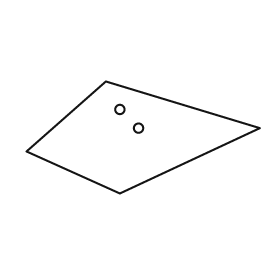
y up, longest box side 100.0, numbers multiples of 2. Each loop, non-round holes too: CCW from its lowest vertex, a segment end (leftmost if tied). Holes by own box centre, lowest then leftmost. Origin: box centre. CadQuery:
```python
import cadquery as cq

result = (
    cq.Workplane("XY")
    .moveTo(-10.0, -24.0)
    .lineTo(50.0, 4.0)
    .lineTo(-16.0, 24.0)
    .lineTo(-50.0, -6.0)
    .close()
    .moveTo(-2.0, 4.0)
    .circle(2.0)
    .moveTo(-10.0, 12.0)
    .circle(2.0)
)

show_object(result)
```